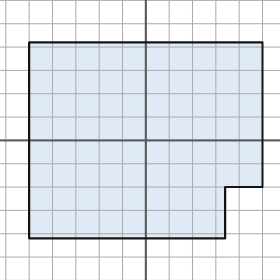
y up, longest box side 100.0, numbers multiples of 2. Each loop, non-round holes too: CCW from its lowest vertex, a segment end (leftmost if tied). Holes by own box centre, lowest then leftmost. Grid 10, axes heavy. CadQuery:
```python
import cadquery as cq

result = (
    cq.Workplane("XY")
    .moveTo(-50.0, -42.0)
    .lineTo(34.0, -42.0)
    .lineTo(34.0, -20.0)
    .lineTo(50.0, -20.0)
    .lineTo(50.0, 42.0)
    .lineTo(-50.0, 42.0)
    .close()
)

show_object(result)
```